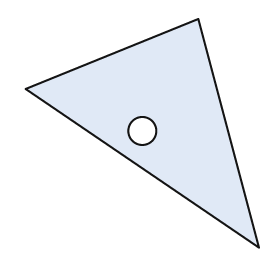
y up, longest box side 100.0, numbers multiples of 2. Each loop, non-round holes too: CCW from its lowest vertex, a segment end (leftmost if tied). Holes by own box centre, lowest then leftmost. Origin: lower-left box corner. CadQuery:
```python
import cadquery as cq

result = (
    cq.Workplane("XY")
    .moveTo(100.0, 0.0)
    .lineTo(74.0, 98.0)
    .lineTo(0.0, 68.0)
    .close()
    .moveTo(50.0, 50.0)
    .circle(6.0)
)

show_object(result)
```